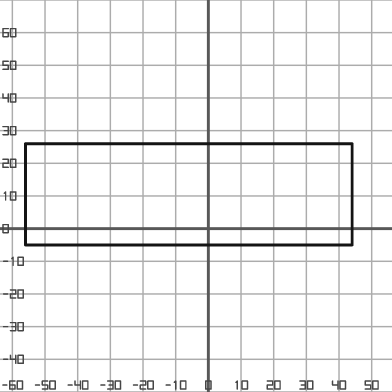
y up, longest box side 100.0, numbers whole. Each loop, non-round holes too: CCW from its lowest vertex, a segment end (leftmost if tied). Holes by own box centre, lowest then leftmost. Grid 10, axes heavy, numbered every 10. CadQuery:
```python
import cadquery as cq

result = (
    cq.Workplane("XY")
    .moveTo(-56.0, -5.0)
    .lineTo(44.0, -5.0)
    .lineTo(44.0, 26.0)
    .lineTo(-56.0, 26.0)
    .close()
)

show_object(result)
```